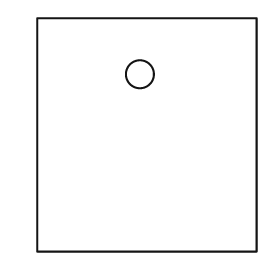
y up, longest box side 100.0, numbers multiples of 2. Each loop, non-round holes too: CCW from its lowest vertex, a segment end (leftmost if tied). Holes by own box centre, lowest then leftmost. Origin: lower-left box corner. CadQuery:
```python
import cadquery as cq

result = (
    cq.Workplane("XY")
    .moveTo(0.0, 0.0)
    .lineTo(94.0, 0.0)
    .lineTo(94.0, 100.0)
    .lineTo(0.0, 100.0)
    .close()
    .moveTo(44.0, 76.0)
    .circle(6.0)
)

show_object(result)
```